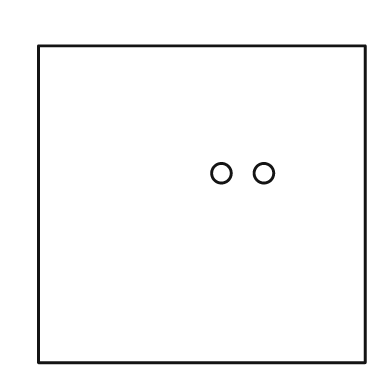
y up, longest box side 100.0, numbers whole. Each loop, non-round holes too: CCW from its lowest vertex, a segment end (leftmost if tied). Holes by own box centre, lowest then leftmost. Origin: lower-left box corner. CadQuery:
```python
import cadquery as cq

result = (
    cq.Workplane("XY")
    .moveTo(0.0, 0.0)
    .lineTo(100.0, 0.0)
    .lineTo(100.0, 97.0)
    .lineTo(0.0, 97.0)
    .close()
    .moveTo(56.0, 58.0)
    .circle(3.0)
    .moveTo(69.0, 58.0)
    .circle(3.0)
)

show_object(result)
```